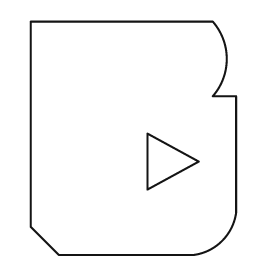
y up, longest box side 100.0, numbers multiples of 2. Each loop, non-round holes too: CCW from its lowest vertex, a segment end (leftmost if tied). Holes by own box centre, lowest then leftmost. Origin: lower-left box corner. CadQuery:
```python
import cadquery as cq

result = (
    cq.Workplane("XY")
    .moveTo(12.0, 0.0)
    .lineTo(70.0, 0.0)
    .threePointArc((82.0, 6.0), (88.0, 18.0))
    .lineTo(88.0, 68.0)
    .lineTo(78.0, 68.0)
    .threePointArc((84.0, 84.0), (78.0, 100.0))
    .lineTo(0.0, 100.0)
    .lineTo(0.0, 12.0)
    .close()
    .moveTo(50.0, 28.0)
    .lineTo(72.0, 40.0)
    .lineTo(50.0, 52.0)
    .close()
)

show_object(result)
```